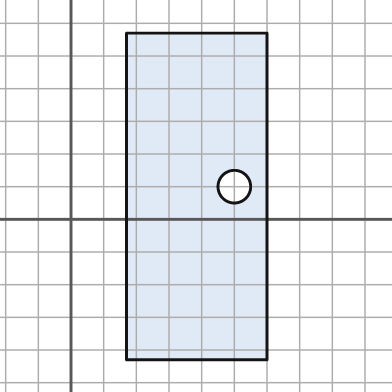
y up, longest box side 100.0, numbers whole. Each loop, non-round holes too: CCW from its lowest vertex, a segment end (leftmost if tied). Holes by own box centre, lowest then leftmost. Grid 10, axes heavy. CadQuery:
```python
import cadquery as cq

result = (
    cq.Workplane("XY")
    .moveTo(17.0, -43.0)
    .lineTo(60.0, -43.0)
    .lineTo(60.0, 57.0)
    .lineTo(17.0, 57.0)
    .close()
    .moveTo(50.0, 10.0)
    .circle(5.0)
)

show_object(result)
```